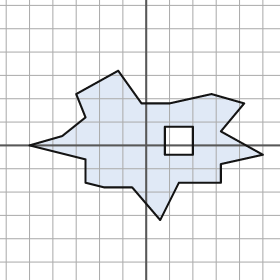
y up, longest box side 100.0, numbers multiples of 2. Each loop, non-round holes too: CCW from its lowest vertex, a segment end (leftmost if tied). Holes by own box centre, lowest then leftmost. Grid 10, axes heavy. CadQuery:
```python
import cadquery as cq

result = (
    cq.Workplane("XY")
    .moveTo(6.0, -32.0)
    .lineTo(14.0, -16.0)
    .lineTo(32.0, -16.0)
    .lineTo(32.0, -8.0)
    .lineTo(50.0, -4.0)
    .lineTo(32.0, 6.0)
    .lineTo(42.0, 18.0)
    .lineTo(28.0, 22.0)
    .lineTo(10.0, 18.0)
    .lineTo(-2.0, 18.0)
    .lineTo(-12.0, 32.0)
    .lineTo(-30.0, 22.0)
    .lineTo(-26.0, 12.0)
    .lineTo(-36.0, 4.0)
    .lineTo(-50.0, 0.0)
    .lineTo(-26.0, -6.0)
    .lineTo(-26.0, -16.0)
    .lineTo(-18.0, -18.0)
    .lineTo(-6.0, -18.0)
    .close()
    .moveTo(8.0, -4.0)
    .lineTo(20.0, -4.0)
    .lineTo(20.0, 8.0)
    .lineTo(8.0, 8.0)
    .close()
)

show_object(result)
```